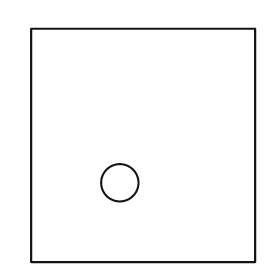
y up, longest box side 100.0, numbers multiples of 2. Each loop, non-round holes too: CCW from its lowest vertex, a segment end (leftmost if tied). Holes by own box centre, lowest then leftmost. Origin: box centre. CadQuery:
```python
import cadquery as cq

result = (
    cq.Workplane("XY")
    .moveTo(-48.0, -50.0)
    .lineTo(48.0, -50.0)
    .lineTo(48.0, 50.0)
    .lineTo(-48.0, 50.0)
    .close()
    .moveTo(-10.0, -16.0)
    .circle(8.0)
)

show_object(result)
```